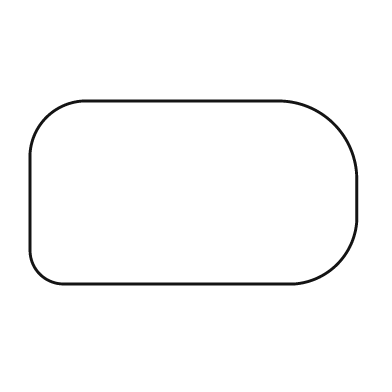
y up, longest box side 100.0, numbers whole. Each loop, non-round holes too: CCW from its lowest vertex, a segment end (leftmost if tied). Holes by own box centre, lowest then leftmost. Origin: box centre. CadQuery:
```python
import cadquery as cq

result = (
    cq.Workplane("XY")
    .moveTo(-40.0, -28.0)
    .lineTo(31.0, -28.0)
    .threePointArc((44.0, -22.0), (50.0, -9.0))
    .lineTo(50.0, 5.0)
    .threePointArc((43.0, 21.0), (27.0, 28.0))
    .lineTo(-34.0, 28.0)
    .threePointArc((-45.0, 23.0), (-50.0, 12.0))
    .lineTo(-50.0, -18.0)
    .threePointArc((-47.0, -25.0), (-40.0, -28.0))
    .close()
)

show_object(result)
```